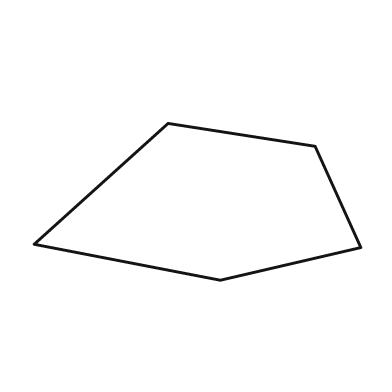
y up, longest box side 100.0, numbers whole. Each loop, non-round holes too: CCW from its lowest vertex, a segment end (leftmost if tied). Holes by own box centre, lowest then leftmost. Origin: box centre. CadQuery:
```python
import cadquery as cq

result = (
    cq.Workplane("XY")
    .moveTo(7.0, -24.0)
    .lineTo(50.0, -14.0)
    .lineTo(36.0, 17.0)
    .lineTo(-9.0, 24.0)
    .lineTo(-50.0, -13.0)
    .close()
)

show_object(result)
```